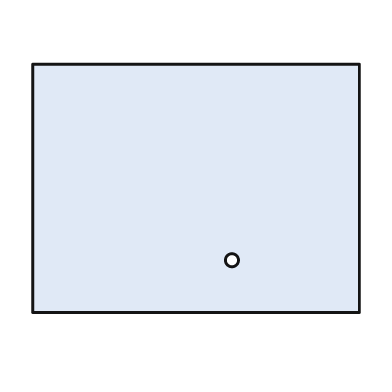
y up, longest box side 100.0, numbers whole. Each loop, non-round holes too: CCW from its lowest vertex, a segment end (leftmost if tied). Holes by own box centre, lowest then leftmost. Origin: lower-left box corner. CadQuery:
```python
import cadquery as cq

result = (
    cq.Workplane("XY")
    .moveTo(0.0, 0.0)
    .lineTo(100.0, 0.0)
    .lineTo(100.0, 76.0)
    .lineTo(0.0, 76.0)
    .close()
    .moveTo(61.0, 16.0)
    .circle(2.0)
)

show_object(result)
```